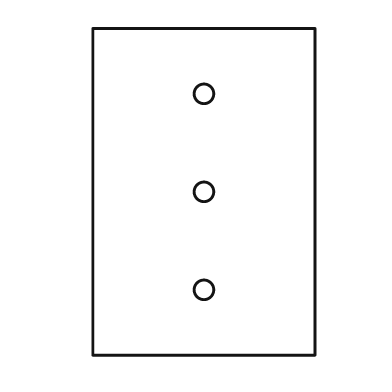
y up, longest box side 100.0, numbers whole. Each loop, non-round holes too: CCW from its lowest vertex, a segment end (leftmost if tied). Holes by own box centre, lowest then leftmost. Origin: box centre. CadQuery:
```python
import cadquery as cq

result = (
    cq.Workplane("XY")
    .moveTo(-34.0, -50.0)
    .lineTo(34.0, -50.0)
    .lineTo(34.0, 50.0)
    .lineTo(-34.0, 50.0)
    .close()
    .moveTo(0.0, -30.0)
    .circle(3.0)
    .moveTo(0.0, 0.0)
    .circle(3.0)
    .moveTo(0.0, 30.0)
    .circle(3.0)
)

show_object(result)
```